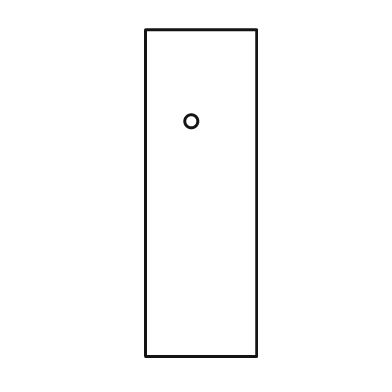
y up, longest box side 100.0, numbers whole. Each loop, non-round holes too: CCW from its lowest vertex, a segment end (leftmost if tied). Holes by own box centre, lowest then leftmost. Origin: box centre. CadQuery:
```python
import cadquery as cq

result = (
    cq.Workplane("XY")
    .moveTo(-17.0, -50.0)
    .lineTo(17.0, -50.0)
    .lineTo(17.0, 50.0)
    .lineTo(-17.0, 50.0)
    .close()
    .moveTo(-3.0, 22.0)
    .circle(2.0)
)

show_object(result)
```